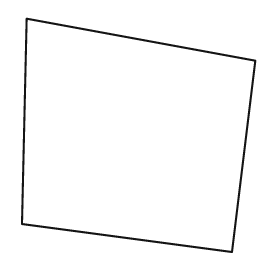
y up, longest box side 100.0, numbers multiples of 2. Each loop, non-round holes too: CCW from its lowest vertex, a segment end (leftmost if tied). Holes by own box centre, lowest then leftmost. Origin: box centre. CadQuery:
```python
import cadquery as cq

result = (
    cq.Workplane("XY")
    .moveTo(40.0, -50.0)
    .lineTo(50.0, 32.0)
    .lineTo(-48.0, 50.0)
    .lineTo(-50.0, -38.0)
    .close()
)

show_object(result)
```